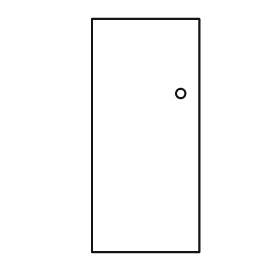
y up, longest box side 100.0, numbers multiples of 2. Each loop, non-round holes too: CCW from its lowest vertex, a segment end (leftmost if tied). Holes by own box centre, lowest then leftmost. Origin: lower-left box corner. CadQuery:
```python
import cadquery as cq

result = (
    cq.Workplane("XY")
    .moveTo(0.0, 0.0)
    .lineTo(46.0, 0.0)
    .lineTo(46.0, 100.0)
    .lineTo(0.0, 100.0)
    .close()
    .moveTo(38.0, 68.0)
    .circle(2.0)
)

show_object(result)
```